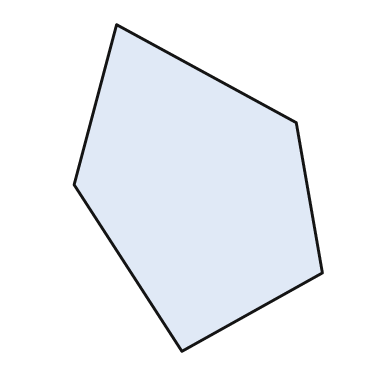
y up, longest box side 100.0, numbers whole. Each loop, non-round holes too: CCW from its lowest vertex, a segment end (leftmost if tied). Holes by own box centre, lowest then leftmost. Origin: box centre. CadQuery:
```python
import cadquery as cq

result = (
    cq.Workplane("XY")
    .moveTo(-5.0, -50.0)
    .lineTo(38.0, -26.0)
    .lineTo(30.0, 20.0)
    .lineTo(-25.0, 50.0)
    .lineTo(-38.0, 1.0)
    .close()
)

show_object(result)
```